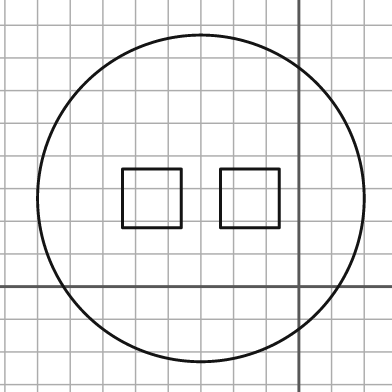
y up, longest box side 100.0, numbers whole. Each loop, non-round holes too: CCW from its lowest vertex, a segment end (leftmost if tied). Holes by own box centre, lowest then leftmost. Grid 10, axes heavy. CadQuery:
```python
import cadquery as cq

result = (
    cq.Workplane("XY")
    .moveTo(-30.0, 27.0)
    .circle(50.0)
    .moveTo(-54.0, 18.0)
    .lineTo(-36.0, 18.0)
    .lineTo(-36.0, 36.0)
    .lineTo(-54.0, 36.0)
    .close()
    .moveTo(-24.0, 18.0)
    .lineTo(-6.0, 18.0)
    .lineTo(-6.0, 36.0)
    .lineTo(-24.0, 36.0)
    .close()
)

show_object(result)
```